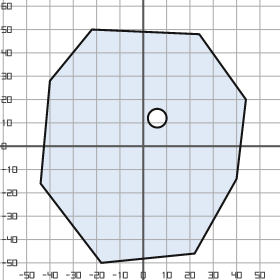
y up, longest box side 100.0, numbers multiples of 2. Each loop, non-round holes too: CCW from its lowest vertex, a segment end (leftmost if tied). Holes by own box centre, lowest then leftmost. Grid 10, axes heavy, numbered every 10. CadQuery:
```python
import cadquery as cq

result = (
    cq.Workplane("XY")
    .moveTo(-18.0, -50.0)
    .lineTo(22.0, -46.0)
    .lineTo(40.0, -14.0)
    .lineTo(44.0, 20.0)
    .lineTo(24.0, 48.0)
    .lineTo(-22.0, 50.0)
    .lineTo(-40.0, 28.0)
    .lineTo(-44.0, -16.0)
    .close()
    .moveTo(6.0, 12.0)
    .circle(4.0)
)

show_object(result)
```